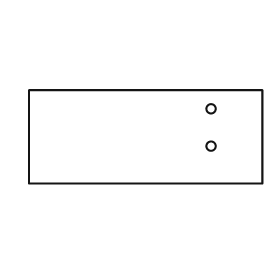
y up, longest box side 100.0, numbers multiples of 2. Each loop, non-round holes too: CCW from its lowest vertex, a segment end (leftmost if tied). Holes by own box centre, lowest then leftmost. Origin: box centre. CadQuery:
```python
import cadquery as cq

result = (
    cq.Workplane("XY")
    .moveTo(-50.0, -20.0)
    .lineTo(50.0, -20.0)
    .lineTo(50.0, 20.0)
    .lineTo(-50.0, 20.0)
    .close()
    .moveTo(28.0, -4.0)
    .circle(2.0)
    .moveTo(28.0, 12.0)
    .circle(2.0)
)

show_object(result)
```